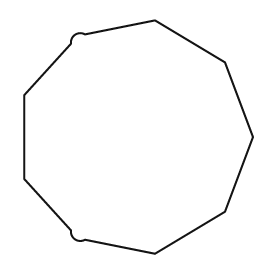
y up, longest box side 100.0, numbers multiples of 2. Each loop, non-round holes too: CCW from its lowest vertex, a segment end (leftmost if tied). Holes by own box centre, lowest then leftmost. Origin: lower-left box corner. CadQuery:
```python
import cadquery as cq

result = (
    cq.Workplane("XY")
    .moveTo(56.0, 0.0)
    .lineTo(86.0, 18.0)
    .lineTo(98.0, 50.0)
    .lineTo(86.0, 82.0)
    .lineTo(56.0, 100.0)
    .lineTo(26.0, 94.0)
    .threePointArc((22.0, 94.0), (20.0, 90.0))
    .lineTo(0.0, 68.0)
    .lineTo(0.0, 32.0)
    .lineTo(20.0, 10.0)
    .threePointArc((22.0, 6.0), (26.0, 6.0))
    .close()
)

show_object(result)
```